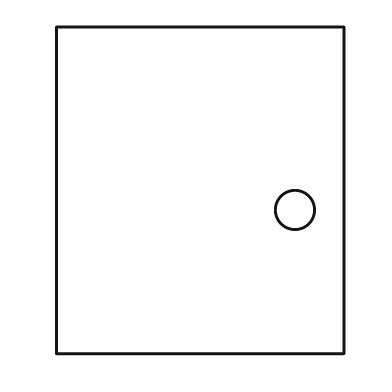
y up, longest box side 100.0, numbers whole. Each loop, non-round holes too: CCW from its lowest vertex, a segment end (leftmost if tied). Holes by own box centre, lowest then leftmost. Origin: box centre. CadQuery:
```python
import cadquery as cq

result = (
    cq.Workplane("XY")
    .moveTo(-44.0, -50.0)
    .lineTo(44.0, -50.0)
    .lineTo(44.0, 50.0)
    .lineTo(-44.0, 50.0)
    .close()
    .moveTo(29.0, -6.0)
    .circle(6.0)
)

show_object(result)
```